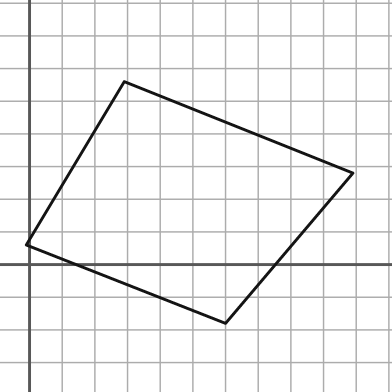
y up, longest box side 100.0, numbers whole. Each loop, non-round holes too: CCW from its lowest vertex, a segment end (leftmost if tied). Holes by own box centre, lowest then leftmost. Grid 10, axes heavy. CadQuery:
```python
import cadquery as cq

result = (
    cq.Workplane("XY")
    .moveTo(60.0, -18.0)
    .lineTo(99.0, 28.0)
    .lineTo(29.0, 56.0)
    .lineTo(-1.0, 6.0)
    .close()
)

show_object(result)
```